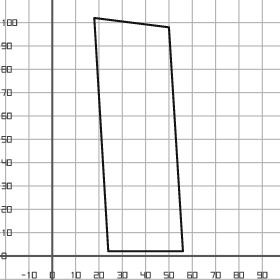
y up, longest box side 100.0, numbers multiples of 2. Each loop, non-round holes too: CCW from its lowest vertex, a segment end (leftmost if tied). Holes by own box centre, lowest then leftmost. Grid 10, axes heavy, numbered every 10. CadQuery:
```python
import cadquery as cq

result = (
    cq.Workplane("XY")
    .moveTo(24.0, 2.0)
    .lineTo(56.0, 2.0)
    .lineTo(50.0, 98.0)
    .lineTo(18.0, 102.0)
    .close()
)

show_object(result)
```